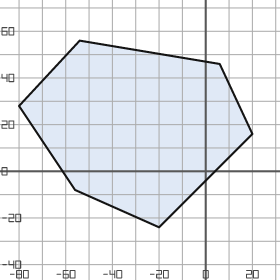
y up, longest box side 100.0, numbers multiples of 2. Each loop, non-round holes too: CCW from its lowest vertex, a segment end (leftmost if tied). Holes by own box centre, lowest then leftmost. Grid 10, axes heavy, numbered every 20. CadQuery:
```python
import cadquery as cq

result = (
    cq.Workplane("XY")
    .moveTo(-20.0, -24.0)
    .lineTo(20.0, 16.0)
    .lineTo(6.0, 46.0)
    .lineTo(-54.0, 56.0)
    .lineTo(-80.0, 28.0)
    .lineTo(-56.0, -8.0)
    .close()
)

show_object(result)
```